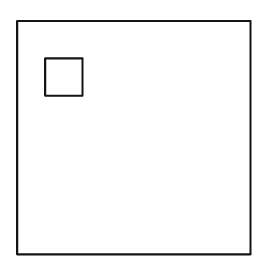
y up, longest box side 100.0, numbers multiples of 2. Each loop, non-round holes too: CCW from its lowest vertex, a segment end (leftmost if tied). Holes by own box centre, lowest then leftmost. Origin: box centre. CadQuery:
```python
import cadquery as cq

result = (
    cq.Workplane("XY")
    .moveTo(-50.0, -50.0)
    .lineTo(50.0, -50.0)
    .lineTo(50.0, 50.0)
    .lineTo(-50.0, 50.0)
    .close()
    .moveTo(-38.0, 18.0)
    .lineTo(-22.0, 18.0)
    .lineTo(-22.0, 34.0)
    .lineTo(-38.0, 34.0)
    .close()
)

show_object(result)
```